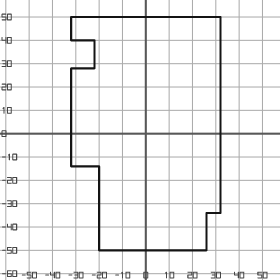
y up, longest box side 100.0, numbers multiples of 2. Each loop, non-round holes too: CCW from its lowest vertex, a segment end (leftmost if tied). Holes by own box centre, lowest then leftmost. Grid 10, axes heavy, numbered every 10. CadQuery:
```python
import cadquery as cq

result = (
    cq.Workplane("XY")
    .moveTo(-20.0, -50.0)
    .lineTo(26.0, -50.0)
    .lineTo(26.0, -34.0)
    .lineTo(32.0, -34.0)
    .lineTo(32.0, 50.0)
    .lineTo(-32.0, 50.0)
    .lineTo(-32.0, 40.0)
    .lineTo(-22.0, 40.0)
    .lineTo(-22.0, 28.0)
    .lineTo(-32.0, 28.0)
    .lineTo(-32.0, -14.0)
    .lineTo(-20.0, -14.0)
    .close()
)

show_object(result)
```